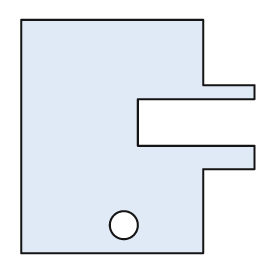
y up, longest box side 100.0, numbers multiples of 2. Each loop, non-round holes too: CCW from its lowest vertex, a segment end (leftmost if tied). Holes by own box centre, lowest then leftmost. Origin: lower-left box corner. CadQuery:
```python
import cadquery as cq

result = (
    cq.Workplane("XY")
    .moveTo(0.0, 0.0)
    .lineTo(78.0, 0.0)
    .lineTo(78.0, 36.0)
    .lineTo(100.0, 36.0)
    .lineTo(100.0, 46.0)
    .lineTo(50.0, 46.0)
    .lineTo(50.0, 66.0)
    .lineTo(100.0, 66.0)
    .lineTo(100.0, 72.0)
    .lineTo(78.0, 72.0)
    .lineTo(78.0, 100.0)
    .lineTo(0.0, 100.0)
    .close()
    .moveTo(44.0, 12.0)
    .circle(6.0)
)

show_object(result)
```